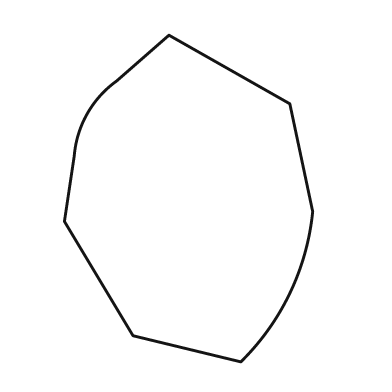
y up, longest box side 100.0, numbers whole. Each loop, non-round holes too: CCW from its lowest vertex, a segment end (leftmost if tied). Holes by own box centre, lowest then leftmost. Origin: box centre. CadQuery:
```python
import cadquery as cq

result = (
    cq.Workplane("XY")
    .moveTo(16.0, -50.0)
    .threePointArc((31.0, -29.0), (38.0, -4.0))
    .lineTo(31.0, 29.0)
    .lineTo(-6.0, 50.0)
    .lineTo(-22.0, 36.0)
    .threePointArc((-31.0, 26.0), (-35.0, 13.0))
    .lineTo(-38.0, -7.0)
    .lineTo(-17.0, -42.0)
    .close()
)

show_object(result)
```